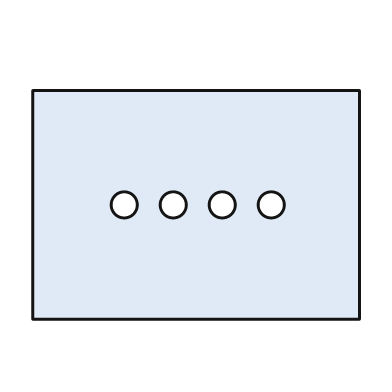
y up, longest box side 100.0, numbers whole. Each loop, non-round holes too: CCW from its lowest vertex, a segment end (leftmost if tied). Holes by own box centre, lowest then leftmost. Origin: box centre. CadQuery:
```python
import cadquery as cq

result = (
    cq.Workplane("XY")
    .moveTo(-50.0, -35.0)
    .lineTo(50.0, -35.0)
    .lineTo(50.0, 35.0)
    .lineTo(-50.0, 35.0)
    .close()
    .moveTo(-22.0, 0.0)
    .circle(4.0)
    .moveTo(-7.0, 0.0)
    .circle(4.0)
    .moveTo(8.0, 0.0)
    .circle(4.0)
    .moveTo(23.0, 0.0)
    .circle(4.0)
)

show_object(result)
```